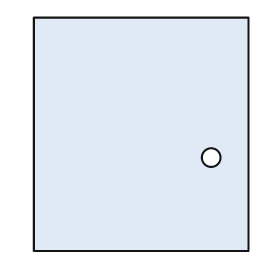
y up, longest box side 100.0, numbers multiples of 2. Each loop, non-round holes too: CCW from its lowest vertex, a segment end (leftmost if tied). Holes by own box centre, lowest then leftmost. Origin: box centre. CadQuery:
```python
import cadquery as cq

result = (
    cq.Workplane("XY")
    .moveTo(-46.0, -50.0)
    .lineTo(46.0, -50.0)
    .lineTo(46.0, 50.0)
    .lineTo(-46.0, 50.0)
    .close()
    .moveTo(30.0, -10.0)
    .circle(4.0)
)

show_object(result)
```